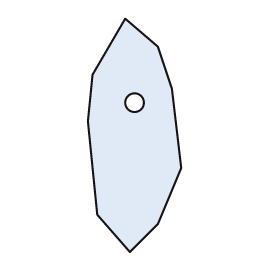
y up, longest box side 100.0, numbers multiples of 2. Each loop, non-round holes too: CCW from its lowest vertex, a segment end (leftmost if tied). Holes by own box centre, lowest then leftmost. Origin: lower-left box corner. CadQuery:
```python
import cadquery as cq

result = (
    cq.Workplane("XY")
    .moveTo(18.0, 0.0)
    .lineTo(30.0, 12.0)
    .lineTo(40.0, 36.0)
    .lineTo(36.0, 70.0)
    .lineTo(30.0, 88.0)
    .lineTo(16.0, 100.0)
    .lineTo(2.0, 76.0)
    .lineTo(0.0, 56.0)
    .lineTo(4.0, 16.0)
    .close()
    .moveTo(20.0, 64.0)
    .circle(4.0)
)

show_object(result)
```